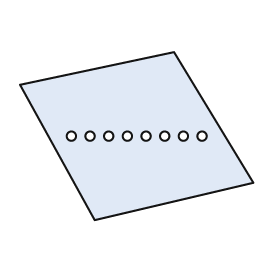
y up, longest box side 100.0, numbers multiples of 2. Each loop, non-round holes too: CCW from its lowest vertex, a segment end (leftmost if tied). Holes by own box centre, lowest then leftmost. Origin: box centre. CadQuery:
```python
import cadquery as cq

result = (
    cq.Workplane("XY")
    .moveTo(-18.0, -36.0)
    .lineTo(50.0, -20.0)
    .lineTo(16.0, 36.0)
    .lineTo(-50.0, 22.0)
    .close()
    .moveTo(-28.0, 0.0)
    .circle(2.0)
    .moveTo(-20.0, 0.0)
    .circle(2.0)
    .moveTo(-12.0, 0.0)
    .circle(2.0)
    .moveTo(-4.0, 0.0)
    .circle(2.0)
    .moveTo(4.0, 0.0)
    .circle(2.0)
    .moveTo(12.0, 0.0)
    .circle(2.0)
    .moveTo(20.0, 0.0)
    .circle(2.0)
    .moveTo(28.0, 0.0)
    .circle(2.0)
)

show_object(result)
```